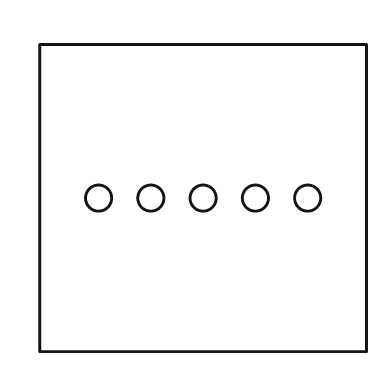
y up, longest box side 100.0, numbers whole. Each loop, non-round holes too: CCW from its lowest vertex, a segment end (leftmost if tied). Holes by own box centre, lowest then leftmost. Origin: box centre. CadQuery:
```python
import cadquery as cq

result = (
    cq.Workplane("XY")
    .moveTo(-50.0, -47.0)
    .lineTo(50.0, -47.0)
    .lineTo(50.0, 47.0)
    .lineTo(-50.0, 47.0)
    .close()
    .moveTo(-32.0, 0.0)
    .circle(4.0)
    .moveTo(-16.0, 0.0)
    .circle(4.0)
    .moveTo(0.0, 0.0)
    .circle(4.0)
    .moveTo(16.0, 0.0)
    .circle(4.0)
    .moveTo(32.0, 0.0)
    .circle(4.0)
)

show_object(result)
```